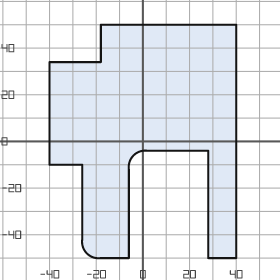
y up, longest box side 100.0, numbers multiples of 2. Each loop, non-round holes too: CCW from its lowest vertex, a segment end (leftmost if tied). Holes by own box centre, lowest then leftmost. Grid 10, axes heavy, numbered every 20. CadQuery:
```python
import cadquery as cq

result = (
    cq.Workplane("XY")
    .moveTo(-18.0, -50.0)
    .lineTo(-6.0, -50.0)
    .lineTo(-6.0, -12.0)
    .threePointArc((-4.0, -6.0), (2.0, -4.0))
    .lineTo(28.0, -4.0)
    .lineTo(28.0, -50.0)
    .lineTo(40.0, -50.0)
    .lineTo(40.0, 50.0)
    .lineTo(-18.0, 50.0)
    .lineTo(-18.0, 34.0)
    .lineTo(-40.0, 34.0)
    .lineTo(-40.0, -10.0)
    .lineTo(-26.0, -10.0)
    .lineTo(-26.0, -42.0)
    .threePointArc((-24.0, -48.0), (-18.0, -50.0))
    .close()
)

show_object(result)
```